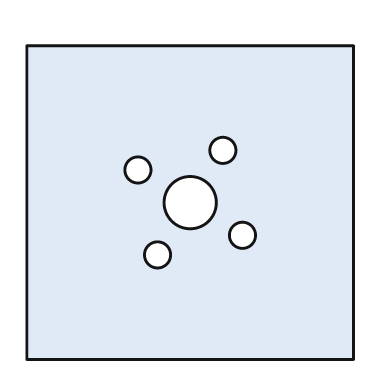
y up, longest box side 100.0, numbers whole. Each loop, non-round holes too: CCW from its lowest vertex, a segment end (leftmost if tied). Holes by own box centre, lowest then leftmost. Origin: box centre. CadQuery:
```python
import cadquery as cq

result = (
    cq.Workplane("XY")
    .moveTo(-50.0, -48.0)
    .lineTo(50.0, -48.0)
    .lineTo(50.0, 48.0)
    .lineTo(-50.0, 48.0)
    .close()
    .moveTo(-10.0, -16.0)
    .circle(4.0)
    .moveTo(16.0, -10.0)
    .circle(4.0)
    .moveTo(0.0, 0.0)
    .circle(8.0)
    .moveTo(-16.0, 10.0)
    .circle(4.0)
    .moveTo(10.0, 16.0)
    .circle(4.0)
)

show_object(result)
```